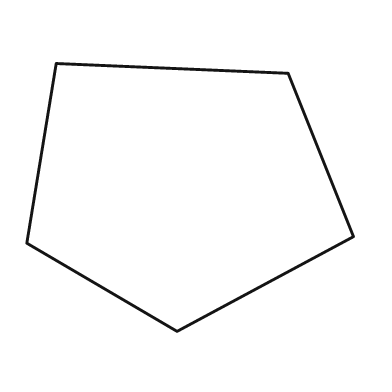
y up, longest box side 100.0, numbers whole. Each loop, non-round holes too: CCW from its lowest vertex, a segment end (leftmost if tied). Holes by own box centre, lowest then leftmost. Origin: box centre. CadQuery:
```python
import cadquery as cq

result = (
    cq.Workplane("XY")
    .moveTo(-4.0, -41.0)
    .lineTo(50.0, -12.0)
    .lineTo(30.0, 38.0)
    .lineTo(-41.0, 41.0)
    .lineTo(-50.0, -14.0)
    .close()
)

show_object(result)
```